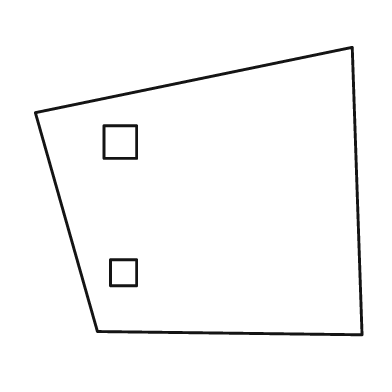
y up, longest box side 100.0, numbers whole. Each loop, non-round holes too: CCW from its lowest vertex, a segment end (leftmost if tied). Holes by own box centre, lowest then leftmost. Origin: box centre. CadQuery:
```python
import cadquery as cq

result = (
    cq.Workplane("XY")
    .moveTo(50.0, -44.0)
    .lineTo(47.0, 44.0)
    .lineTo(-50.0, 24.0)
    .lineTo(-31.0, -43.0)
    .close()
    .moveTo(-27.0, -29.0)
    .lineTo(-19.0, -29.0)
    .lineTo(-19.0, -21.0)
    .lineTo(-27.0, -21.0)
    .close()
    .moveTo(-29.0, 10.0)
    .lineTo(-19.0, 10.0)
    .lineTo(-19.0, 20.0)
    .lineTo(-29.0, 20.0)
    .close()
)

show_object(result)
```